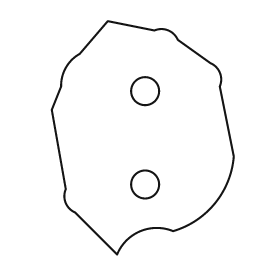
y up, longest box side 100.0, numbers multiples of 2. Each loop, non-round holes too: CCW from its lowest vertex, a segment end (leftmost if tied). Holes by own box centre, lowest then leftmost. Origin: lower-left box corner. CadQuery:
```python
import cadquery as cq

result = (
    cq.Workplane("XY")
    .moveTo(28.0, 0.0)
    .threePointArc((38.0, 10.0), (52.0, 10.0))
    .threePointArc((70.0, 22.0), (78.0, 42.0))
    .lineTo(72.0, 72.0)
    .threePointArc((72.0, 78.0), (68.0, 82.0))
    .lineTo(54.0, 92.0)
    .threePointArc((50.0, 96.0), (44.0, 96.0))
    .lineTo(24.0, 100.0)
    .lineTo(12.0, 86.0)
    .threePointArc((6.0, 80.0), (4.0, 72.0))
    .lineTo(0.0, 62.0)
    .lineTo(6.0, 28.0)
    .threePointArc((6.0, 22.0), (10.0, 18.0))
    .close()
    .moveTo(40.0, 30.0)
    .circle(6.0)
    .moveTo(40.0, 70.0)
    .circle(6.0)
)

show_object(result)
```